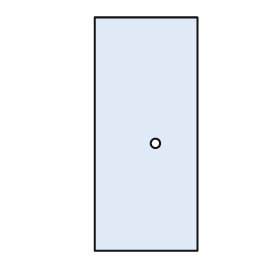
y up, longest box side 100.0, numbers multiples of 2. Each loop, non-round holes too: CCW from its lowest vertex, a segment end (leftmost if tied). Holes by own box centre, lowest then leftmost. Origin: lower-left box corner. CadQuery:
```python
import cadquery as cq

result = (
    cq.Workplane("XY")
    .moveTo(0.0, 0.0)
    .lineTo(44.0, 0.0)
    .lineTo(44.0, 100.0)
    .lineTo(0.0, 100.0)
    .close()
    .moveTo(26.0, 46.0)
    .circle(2.0)
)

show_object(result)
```